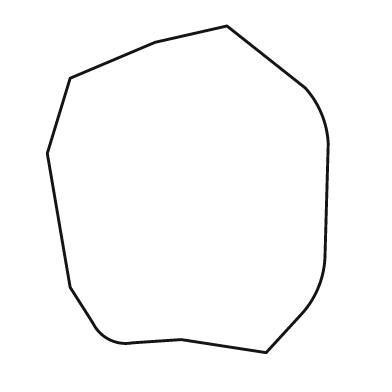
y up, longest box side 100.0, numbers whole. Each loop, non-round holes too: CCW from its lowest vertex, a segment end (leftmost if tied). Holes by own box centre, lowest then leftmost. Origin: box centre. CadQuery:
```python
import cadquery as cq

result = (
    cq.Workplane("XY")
    .moveTo(24.0, -50.0)
    .lineTo(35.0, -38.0)
    .threePointArc((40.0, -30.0), (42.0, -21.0))
    .lineTo(43.0, 14.0)
    .threePointArc((41.0, 23.0), (36.0, 31.0))
    .lineTo(12.0, 50.0)
    .lineTo(-10.0, 45.0)
    .lineTo(-36.0, 34.0)
    .lineTo(-43.0, 11.0)
    .lineTo(-36.0, -30.0)
    .lineTo(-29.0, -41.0)
    .threePointArc((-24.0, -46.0), (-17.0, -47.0))
    .lineTo(-2.0, -46.0)
    .close()
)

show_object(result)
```